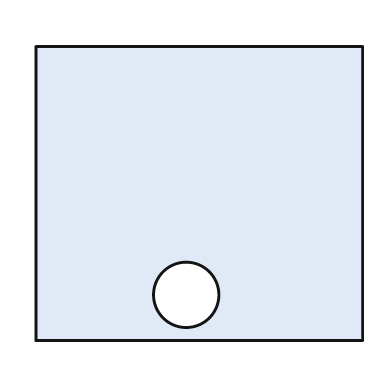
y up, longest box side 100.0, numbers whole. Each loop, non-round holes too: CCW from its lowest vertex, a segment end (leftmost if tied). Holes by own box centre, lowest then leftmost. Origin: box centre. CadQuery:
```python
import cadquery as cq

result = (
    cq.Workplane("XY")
    .moveTo(-50.0, -45.0)
    .lineTo(50.0, -45.0)
    .lineTo(50.0, 45.0)
    .lineTo(-50.0, 45.0)
    .close()
    .moveTo(-4.0, -31.0)
    .circle(10.0)
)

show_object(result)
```